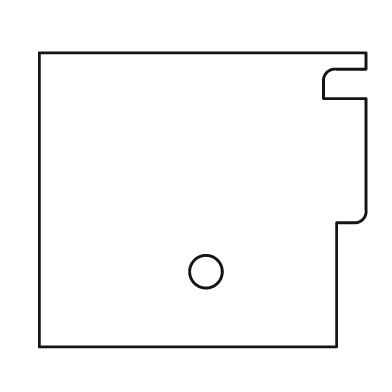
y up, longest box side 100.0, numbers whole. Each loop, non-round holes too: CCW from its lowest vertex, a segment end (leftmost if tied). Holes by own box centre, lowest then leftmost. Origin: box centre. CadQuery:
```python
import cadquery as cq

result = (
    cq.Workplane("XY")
    .moveTo(-50.0, -45.0)
    .lineTo(41.0, -45.0)
    .lineTo(41.0, -7.0)
    .lineTo(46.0, -7.0)
    .threePointArc((49.0, -6.0), (50.0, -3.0))
    .lineTo(50.0, 31.0)
    .lineTo(37.0, 31.0)
    .lineTo(37.0, 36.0)
    .threePointArc((38.0, 39.0), (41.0, 40.0))
    .lineTo(50.0, 40.0)
    .lineTo(50.0, 45.0)
    .lineTo(-50.0, 45.0)
    .close()
    .moveTo(1.0, -22.0)
    .circle(5.0)
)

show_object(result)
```